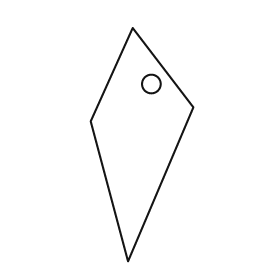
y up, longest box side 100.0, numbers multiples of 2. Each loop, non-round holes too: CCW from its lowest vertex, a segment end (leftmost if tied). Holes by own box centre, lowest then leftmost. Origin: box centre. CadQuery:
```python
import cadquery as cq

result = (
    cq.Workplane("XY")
    .moveTo(-6.0, -50.0)
    .lineTo(22.0, 16.0)
    .lineTo(-4.0, 50.0)
    .lineTo(-22.0, 10.0)
    .close()
    .moveTo(4.0, 26.0)
    .circle(4.0)
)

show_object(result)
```